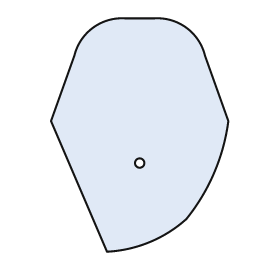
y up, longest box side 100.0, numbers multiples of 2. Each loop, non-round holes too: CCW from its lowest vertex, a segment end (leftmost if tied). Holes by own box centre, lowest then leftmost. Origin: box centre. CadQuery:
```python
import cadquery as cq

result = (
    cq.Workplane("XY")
    .moveTo(-14.0, -50.0)
    .threePointArc((4.0, -46.0), (20.0, -36.0))
    .threePointArc((32.0, -16.0), (38.0, 6.0))
    .lineTo(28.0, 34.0)
    .threePointArc((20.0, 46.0), (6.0, 50.0))
    .lineTo(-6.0, 50.0)
    .threePointArc((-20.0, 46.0), (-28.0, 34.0))
    .lineTo(-38.0, 6.0)
    .close()
    .moveTo(0.0, -12.0)
    .circle(2.0)
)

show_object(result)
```